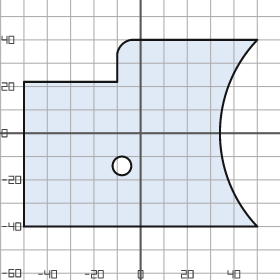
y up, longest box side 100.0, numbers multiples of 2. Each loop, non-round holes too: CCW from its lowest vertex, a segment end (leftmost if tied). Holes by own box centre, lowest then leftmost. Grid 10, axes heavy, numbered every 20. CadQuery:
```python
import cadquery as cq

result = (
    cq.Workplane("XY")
    .moveTo(-50.0, -40.0)
    .lineTo(50.0, -40.0)
    .threePointArc((34.0, 0.0), (50.0, 40.0))
    .lineTo(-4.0, 40.0)
    .threePointArc((-8.0, 38.0), (-10.0, 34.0))
    .lineTo(-10.0, 22.0)
    .lineTo(-50.0, 22.0)
    .close()
    .moveTo(-8.0, -14.0)
    .circle(4.0)
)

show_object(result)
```